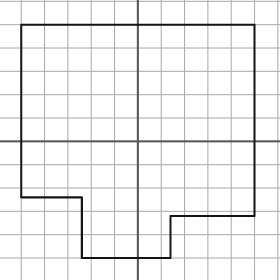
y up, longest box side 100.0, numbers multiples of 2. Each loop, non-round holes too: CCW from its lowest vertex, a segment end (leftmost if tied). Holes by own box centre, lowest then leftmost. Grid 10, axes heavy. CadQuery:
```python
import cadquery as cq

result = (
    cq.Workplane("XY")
    .moveTo(-24.0, -50.0)
    .lineTo(14.0, -50.0)
    .lineTo(14.0, -32.0)
    .lineTo(50.0, -32.0)
    .lineTo(50.0, 50.0)
    .lineTo(-50.0, 50.0)
    .lineTo(-50.0, -24.0)
    .lineTo(-24.0, -24.0)
    .close()
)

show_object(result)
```